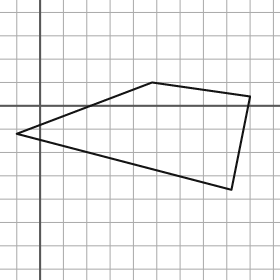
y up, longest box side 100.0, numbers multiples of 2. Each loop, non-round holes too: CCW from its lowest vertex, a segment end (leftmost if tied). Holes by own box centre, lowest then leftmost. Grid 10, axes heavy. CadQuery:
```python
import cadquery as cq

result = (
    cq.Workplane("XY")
    .moveTo(82.0, -36.0)
    .lineTo(90.0, 4.0)
    .lineTo(48.0, 10.0)
    .lineTo(-10.0, -12.0)
    .close()
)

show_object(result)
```